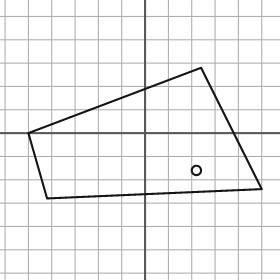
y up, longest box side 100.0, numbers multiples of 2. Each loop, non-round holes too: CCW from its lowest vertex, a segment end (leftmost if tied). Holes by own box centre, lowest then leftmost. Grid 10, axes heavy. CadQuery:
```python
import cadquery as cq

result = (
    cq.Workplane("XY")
    .moveTo(-42.0, -28.0)
    .lineTo(50.0, -24.0)
    .lineTo(24.0, 28.0)
    .lineTo(-50.0, 0.0)
    .close()
    .moveTo(22.0, -16.0)
    .circle(2.0)
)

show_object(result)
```